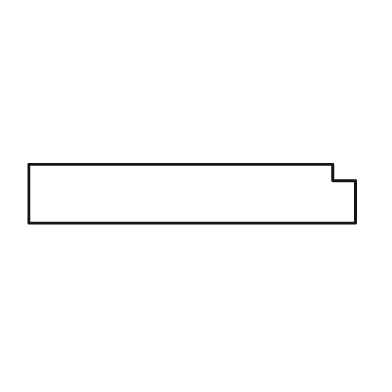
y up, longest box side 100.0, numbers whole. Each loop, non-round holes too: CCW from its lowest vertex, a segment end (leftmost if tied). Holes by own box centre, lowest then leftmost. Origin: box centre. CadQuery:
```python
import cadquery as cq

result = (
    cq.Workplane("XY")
    .moveTo(-50.0, -9.0)
    .lineTo(50.0, -9.0)
    .lineTo(50.0, 4.0)
    .lineTo(43.0, 4.0)
    .lineTo(43.0, 9.0)
    .lineTo(-50.0, 9.0)
    .close()
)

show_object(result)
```